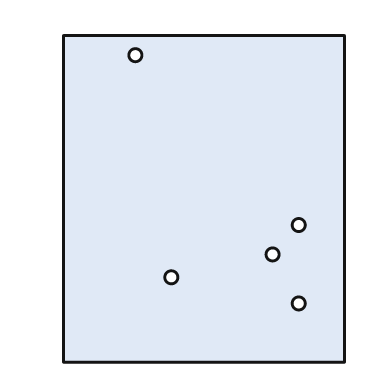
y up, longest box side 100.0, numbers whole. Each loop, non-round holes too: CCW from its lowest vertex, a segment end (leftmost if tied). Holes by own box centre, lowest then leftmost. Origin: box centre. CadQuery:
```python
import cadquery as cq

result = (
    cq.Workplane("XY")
    .moveTo(-43.0, -50.0)
    .lineTo(43.0, -50.0)
    .lineTo(43.0, 50.0)
    .lineTo(-43.0, 50.0)
    .close()
    .moveTo(29.0, -32.0)
    .circle(2.0)
    .moveTo(-10.0, -24.0)
    .circle(2.0)
    .moveTo(21.0, -17.0)
    .circle(2.0)
    .moveTo(29.0, -8.0)
    .circle(2.0)
    .moveTo(-21.0, 44.0)
    .circle(2.0)
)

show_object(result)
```